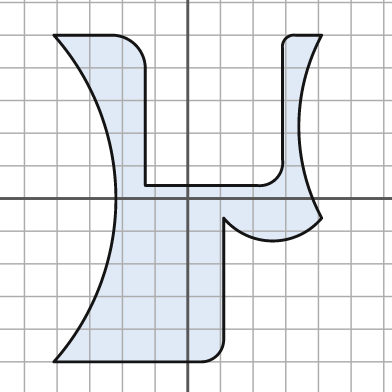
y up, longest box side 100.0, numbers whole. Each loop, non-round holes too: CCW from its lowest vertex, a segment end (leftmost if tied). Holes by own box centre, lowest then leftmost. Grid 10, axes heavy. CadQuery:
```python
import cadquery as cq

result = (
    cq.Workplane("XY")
    .moveTo(-41.0, -50.0)
    .lineTo(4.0, -50.0)
    .threePointArc((9.0, -48.0), (11.0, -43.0))
    .lineTo(11.0, -6.0)
    .threePointArc((26.0, -13.0), (41.0, -6.0))
    .threePointArc((34.0, 22.0), (41.0, 50.0))
    .lineTo(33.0, 50.0)
    .threePointArc((30.0, 49.0), (29.0, 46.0))
    .lineTo(29.0, 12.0)
    .threePointArc((27.0, 6.0), (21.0, 4.0))
    .lineTo(-13.0, 4.0)
    .lineTo(-13.0, 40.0)
    .threePointArc((-16.0, 47.0), (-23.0, 50.0))
    .lineTo(-41.0, 50.0)
    .threePointArc((-22.0, 0.0), (-41.0, -50.0))
    .close()
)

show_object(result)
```